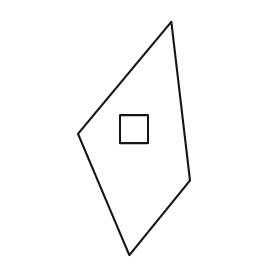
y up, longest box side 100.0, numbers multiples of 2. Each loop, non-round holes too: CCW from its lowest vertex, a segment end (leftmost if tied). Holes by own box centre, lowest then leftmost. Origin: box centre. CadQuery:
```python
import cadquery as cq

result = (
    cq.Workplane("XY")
    .moveTo(-2.0, -50.0)
    .lineTo(24.0, -18.0)
    .lineTo(16.0, 50.0)
    .lineTo(-24.0, 2.0)
    .close()
    .moveTo(-6.0, -2.0)
    .lineTo(6.0, -2.0)
    .lineTo(6.0, 10.0)
    .lineTo(-6.0, 10.0)
    .close()
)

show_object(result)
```